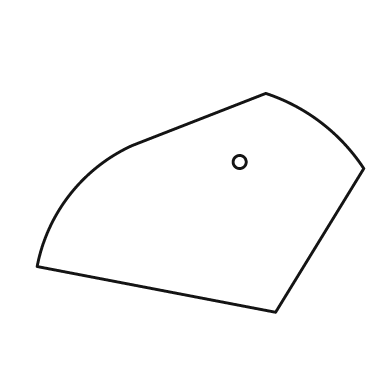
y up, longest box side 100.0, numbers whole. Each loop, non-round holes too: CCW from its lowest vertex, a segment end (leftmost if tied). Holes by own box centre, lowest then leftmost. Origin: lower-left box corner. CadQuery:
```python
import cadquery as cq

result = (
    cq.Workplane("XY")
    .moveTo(73.0, 0.0)
    .lineTo(100.0, 44.0)
    .threePointArc((87.0, 58.0), (70.0, 67.0))
    .lineTo(29.0, 51.0)
    .threePointArc((10.0, 36.0), (0.0, 14.0))
    .close()
    .moveTo(62.0, 46.0)
    .circle(2.0)
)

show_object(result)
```